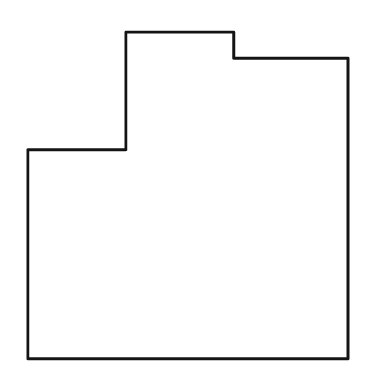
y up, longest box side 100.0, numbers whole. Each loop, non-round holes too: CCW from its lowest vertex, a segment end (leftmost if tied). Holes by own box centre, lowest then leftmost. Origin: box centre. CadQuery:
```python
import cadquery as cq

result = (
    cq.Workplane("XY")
    .moveTo(-49.0, -50.0)
    .lineTo(49.0, -50.0)
    .lineTo(49.0, 42.0)
    .lineTo(14.0, 42.0)
    .lineTo(14.0, 50.0)
    .lineTo(-19.0, 50.0)
    .lineTo(-19.0, 14.0)
    .lineTo(-49.0, 14.0)
    .close()
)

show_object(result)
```